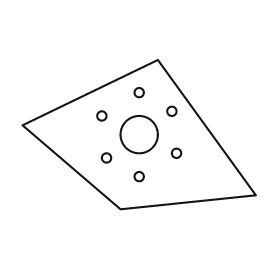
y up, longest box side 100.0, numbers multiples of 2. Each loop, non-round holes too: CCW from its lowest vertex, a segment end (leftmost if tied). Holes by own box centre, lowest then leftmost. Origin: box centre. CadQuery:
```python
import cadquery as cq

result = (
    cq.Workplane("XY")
    .moveTo(-8.0, -32.0)
    .lineTo(50.0, -26.0)
    .lineTo(8.0, 32.0)
    .lineTo(-50.0, 4.0)
    .close()
    .moveTo(0.0, -18.0)
    .circle(2.0)
    .moveTo(-14.0, -10.0)
    .circle(2.0)
    .moveTo(16.0, -8.0)
    .circle(2.0)
    .moveTo(0.0, 0.0)
    .circle(8.0)
    .moveTo(-16.0, 8.0)
    .circle(2.0)
    .moveTo(14.0, 10.0)
    .circle(2.0)
    .moveTo(0.0, 18.0)
    .circle(2.0)
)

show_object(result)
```